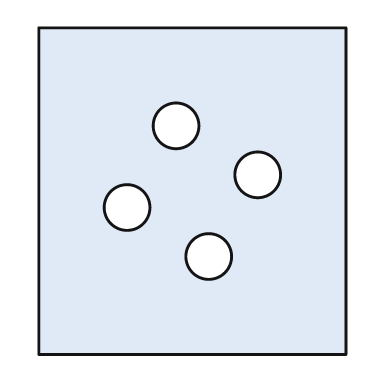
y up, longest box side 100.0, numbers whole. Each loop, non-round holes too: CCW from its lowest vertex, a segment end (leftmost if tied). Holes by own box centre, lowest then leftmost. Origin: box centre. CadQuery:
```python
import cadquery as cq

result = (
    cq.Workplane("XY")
    .moveTo(-47.0, -50.0)
    .lineTo(47.0, -50.0)
    .lineTo(47.0, 50.0)
    .lineTo(-47.0, 50.0)
    .close()
    .moveTo(5.0, -20.0)
    .circle(7.0)
    .moveTo(-20.0, -5.0)
    .circle(7.0)
    .moveTo(20.0, 5.0)
    .circle(7.0)
    .moveTo(-5.0, 20.0)
    .circle(7.0)
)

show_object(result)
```